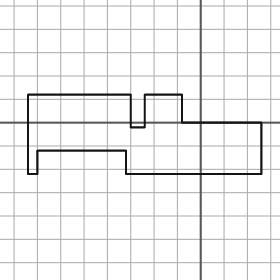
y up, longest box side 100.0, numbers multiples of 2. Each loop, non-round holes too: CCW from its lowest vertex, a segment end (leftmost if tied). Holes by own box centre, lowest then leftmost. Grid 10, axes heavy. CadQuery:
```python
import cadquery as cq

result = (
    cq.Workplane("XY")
    .moveTo(-74.0, -22.0)
    .lineTo(-70.0, -22.0)
    .lineTo(-70.0, -12.0)
    .lineTo(-32.0, -12.0)
    .lineTo(-32.0, -22.0)
    .lineTo(26.0, -22.0)
    .lineTo(26.0, 0.0)
    .lineTo(-8.0, 0.0)
    .lineTo(-8.0, 12.0)
    .lineTo(-24.0, 12.0)
    .lineTo(-24.0, -2.0)
    .lineTo(-30.0, -2.0)
    .lineTo(-30.0, 12.0)
    .lineTo(-74.0, 12.0)
    .close()
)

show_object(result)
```